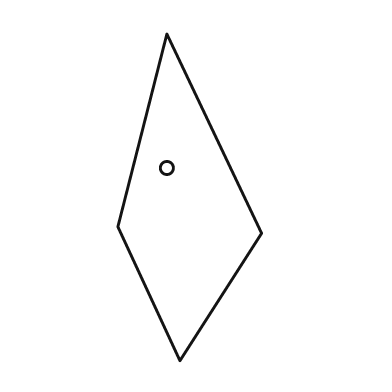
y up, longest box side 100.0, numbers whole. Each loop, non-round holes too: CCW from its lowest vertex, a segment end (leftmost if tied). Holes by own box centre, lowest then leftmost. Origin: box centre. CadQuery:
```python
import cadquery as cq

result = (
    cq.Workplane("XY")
    .moveTo(-3.0, -50.0)
    .lineTo(22.0, -11.0)
    .lineTo(-7.0, 50.0)
    .lineTo(-22.0, -9.0)
    .close()
    .moveTo(-7.0, 9.0)
    .circle(2.0)
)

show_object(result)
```